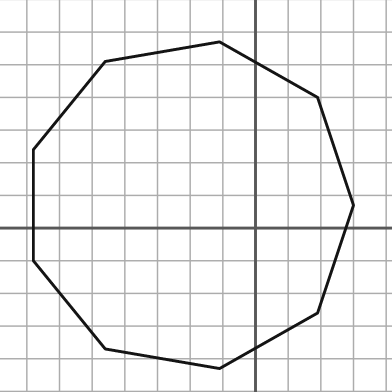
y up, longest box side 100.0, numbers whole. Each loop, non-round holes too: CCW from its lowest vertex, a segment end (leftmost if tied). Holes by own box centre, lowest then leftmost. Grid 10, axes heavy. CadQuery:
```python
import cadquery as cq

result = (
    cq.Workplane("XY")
    .moveTo(-11.0, -43.0)
    .lineTo(19.0, -26.0)
    .lineTo(30.0, 7.0)
    .lineTo(19.0, 40.0)
    .lineTo(-11.0, 57.0)
    .lineTo(-46.0, 51.0)
    .lineTo(-68.0, 24.0)
    .lineTo(-68.0, -10.0)
    .lineTo(-46.0, -37.0)
    .close()
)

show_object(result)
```